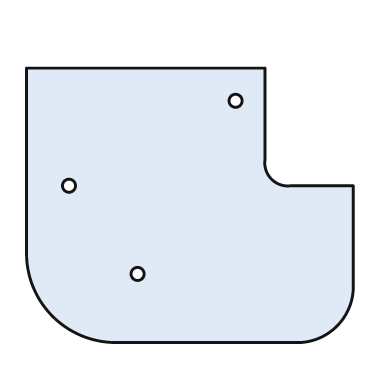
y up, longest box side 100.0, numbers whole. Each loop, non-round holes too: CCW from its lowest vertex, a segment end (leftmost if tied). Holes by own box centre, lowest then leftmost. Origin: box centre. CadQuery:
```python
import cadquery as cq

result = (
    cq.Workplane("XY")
    .moveTo(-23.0, -42.0)
    .lineTo(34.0, -42.0)
    .threePointArc((45.0, -37.0), (50.0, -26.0))
    .lineTo(50.0, 6.0)
    .lineTo(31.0, 6.0)
    .threePointArc((25.0, 8.0), (23.0, 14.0))
    .lineTo(23.0, 42.0)
    .lineTo(-50.0, 42.0)
    .lineTo(-50.0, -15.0)
    .threePointArc((-42.0, -34.0), (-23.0, -42.0))
    .close()
    .moveTo(-16.0, -21.0)
    .circle(2.0)
    .moveTo(-37.0, 6.0)
    .circle(2.0)
    .moveTo(14.0, 32.0)
    .circle(2.0)
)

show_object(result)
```